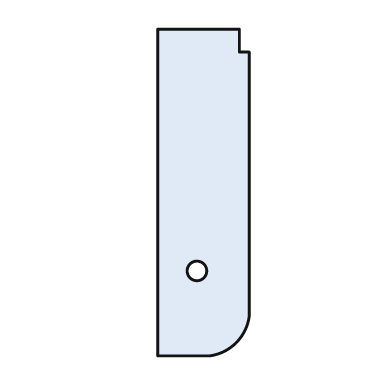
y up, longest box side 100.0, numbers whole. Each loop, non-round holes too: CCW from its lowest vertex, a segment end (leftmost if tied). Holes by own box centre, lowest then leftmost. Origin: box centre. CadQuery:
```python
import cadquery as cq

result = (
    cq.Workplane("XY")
    .moveTo(-14.0, -50.0)
    .lineTo(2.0, -50.0)
    .threePointArc((10.0, -46.0), (14.0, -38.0))
    .lineTo(14.0, 43.0)
    .lineTo(11.0, 43.0)
    .lineTo(11.0, 50.0)
    .lineTo(-14.0, 50.0)
    .close()
    .moveTo(-2.0, -24.0)
    .circle(3.0)
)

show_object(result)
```